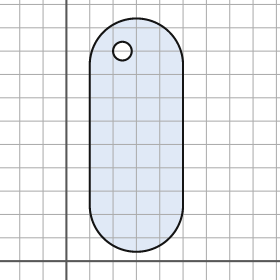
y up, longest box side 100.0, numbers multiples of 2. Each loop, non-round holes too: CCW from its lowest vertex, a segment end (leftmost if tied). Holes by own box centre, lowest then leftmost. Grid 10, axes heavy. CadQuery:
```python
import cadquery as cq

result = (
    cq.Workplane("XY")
    .moveTo(10.0, 24.0)
    .threePointArc((30.0, 4.0), (50.0, 24.0))
    .lineTo(50.0, 84.0)
    .threePointArc((30.0, 104.0), (10.0, 84.0))
    .close()
    .moveTo(24.0, 90.0)
    .circle(4.0)
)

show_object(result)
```